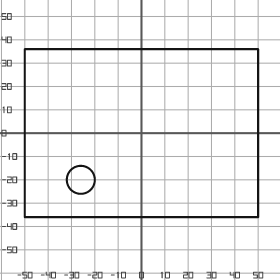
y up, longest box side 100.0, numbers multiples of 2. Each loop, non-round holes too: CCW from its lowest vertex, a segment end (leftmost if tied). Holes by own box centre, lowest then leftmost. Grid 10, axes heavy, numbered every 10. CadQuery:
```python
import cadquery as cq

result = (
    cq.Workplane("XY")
    .moveTo(-50.0, -36.0)
    .lineTo(50.0, -36.0)
    .lineTo(50.0, 36.0)
    .lineTo(-50.0, 36.0)
    .close()
    .moveTo(-26.0, -20.0)
    .circle(6.0)
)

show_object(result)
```